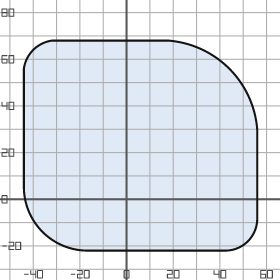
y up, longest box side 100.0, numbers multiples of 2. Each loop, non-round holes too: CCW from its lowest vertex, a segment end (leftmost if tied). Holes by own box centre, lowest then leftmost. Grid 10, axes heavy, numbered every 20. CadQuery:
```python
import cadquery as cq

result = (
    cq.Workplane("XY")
    .moveTo(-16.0, -22.0)
    .lineTo(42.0, -22.0)
    .threePointArc((52.0, -18.0), (56.0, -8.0))
    .lineTo(56.0, 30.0)
    .threePointArc((44.0, 56.0), (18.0, 68.0))
    .lineTo(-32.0, 68.0)
    .threePointArc((-40.0, 64.0), (-44.0, 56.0))
    .lineTo(-44.0, 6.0)
    .threePointArc((-36.0, -14.0), (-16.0, -22.0))
    .close()
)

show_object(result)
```